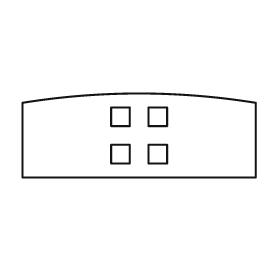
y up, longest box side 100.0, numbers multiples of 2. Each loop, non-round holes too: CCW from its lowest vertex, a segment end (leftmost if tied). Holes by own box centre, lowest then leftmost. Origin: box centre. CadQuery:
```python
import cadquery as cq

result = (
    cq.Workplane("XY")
    .moveTo(-50.0, -18.0)
    .lineTo(50.0, -18.0)
    .lineTo(50.0, 14.0)
    .threePointArc((0.0, 18.0), (-50.0, 14.0))
    .close()
    .moveTo(-12.0, -12.0)
    .lineTo(-4.0, -12.0)
    .lineTo(-4.0, -4.0)
    .lineTo(-12.0, -4.0)
    .close()
    .moveTo(4.0, -12.0)
    .lineTo(12.0, -12.0)
    .lineTo(12.0, -4.0)
    .lineTo(4.0, -4.0)
    .close()
    .moveTo(-12.0, 4.0)
    .lineTo(-4.0, 4.0)
    .lineTo(-4.0, 12.0)
    .lineTo(-12.0, 12.0)
    .close()
    .moveTo(4.0, 4.0)
    .lineTo(12.0, 4.0)
    .lineTo(12.0, 12.0)
    .lineTo(4.0, 12.0)
    .close()
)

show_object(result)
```